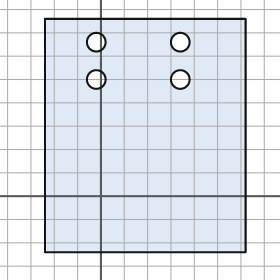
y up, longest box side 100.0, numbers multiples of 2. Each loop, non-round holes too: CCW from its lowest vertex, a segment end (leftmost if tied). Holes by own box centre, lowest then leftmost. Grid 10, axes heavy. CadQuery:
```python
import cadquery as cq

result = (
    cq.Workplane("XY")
    .moveTo(-24.0, -24.0)
    .lineTo(62.0, -24.0)
    .lineTo(62.0, 76.0)
    .lineTo(-24.0, 76.0)
    .close()
    .moveTo(-2.0, 50.0)
    .circle(4.0)
    .moveTo(34.0, 50.0)
    .circle(4.0)
    .moveTo(-2.0, 66.0)
    .circle(4.0)
    .moveTo(34.0, 66.0)
    .circle(4.0)
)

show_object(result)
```